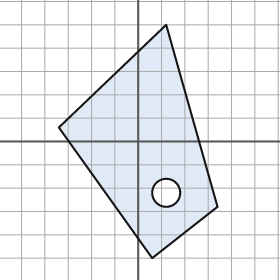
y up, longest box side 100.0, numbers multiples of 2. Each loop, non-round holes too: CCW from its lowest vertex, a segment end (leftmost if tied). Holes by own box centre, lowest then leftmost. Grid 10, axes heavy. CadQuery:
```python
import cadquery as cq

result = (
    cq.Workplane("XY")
    .moveTo(6.0, -50.0)
    .lineTo(34.0, -28.0)
    .lineTo(12.0, 50.0)
    .lineTo(-34.0, 6.0)
    .close()
    .moveTo(12.0, -22.0)
    .circle(6.0)
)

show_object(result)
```